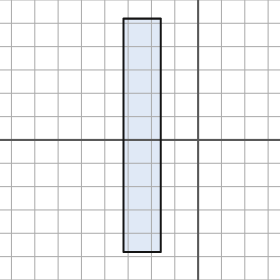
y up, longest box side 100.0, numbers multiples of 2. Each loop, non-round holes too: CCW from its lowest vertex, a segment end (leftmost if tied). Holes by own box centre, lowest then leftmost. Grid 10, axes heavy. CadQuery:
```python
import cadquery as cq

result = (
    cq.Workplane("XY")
    .moveTo(-32.0, -48.0)
    .lineTo(-16.0, -48.0)
    .lineTo(-16.0, 52.0)
    .lineTo(-32.0, 52.0)
    .close()
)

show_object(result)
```